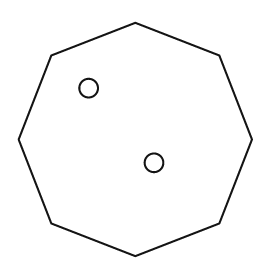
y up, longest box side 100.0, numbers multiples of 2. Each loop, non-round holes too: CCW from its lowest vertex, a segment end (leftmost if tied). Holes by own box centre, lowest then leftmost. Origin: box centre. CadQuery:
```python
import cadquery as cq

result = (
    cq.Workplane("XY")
    .moveTo(0.0, -50.0)
    .lineTo(36.0, -36.0)
    .lineTo(50.0, 0.0)
    .lineTo(36.0, 36.0)
    .lineTo(0.0, 50.0)
    .lineTo(-36.0, 36.0)
    .lineTo(-50.0, 0.0)
    .lineTo(-36.0, -36.0)
    .close()
    .moveTo(8.0, -10.0)
    .circle(4.0)
    .moveTo(-20.0, 22.0)
    .circle(4.0)
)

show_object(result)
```